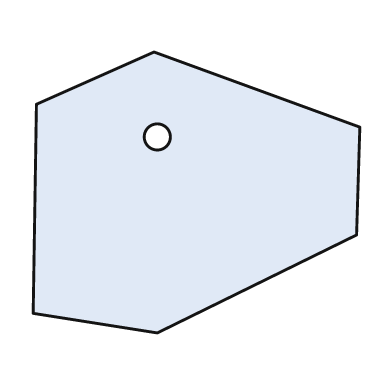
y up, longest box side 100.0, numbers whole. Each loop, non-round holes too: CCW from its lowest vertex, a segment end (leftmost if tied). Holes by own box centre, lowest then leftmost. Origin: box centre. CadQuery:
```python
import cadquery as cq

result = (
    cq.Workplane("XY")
    .moveTo(-12.0, -43.0)
    .lineTo(49.0, -13.0)
    .lineTo(50.0, 20.0)
    .lineTo(-13.0, 43.0)
    .lineTo(-49.0, 27.0)
    .lineTo(-50.0, -37.0)
    .close()
    .moveTo(-12.0, 17.0)
    .circle(4.0)
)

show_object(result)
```